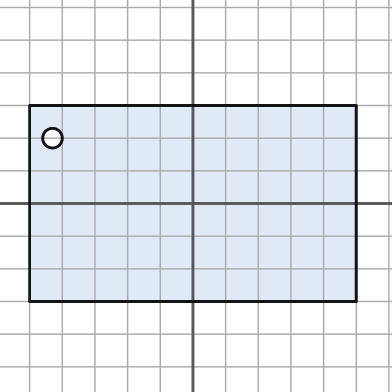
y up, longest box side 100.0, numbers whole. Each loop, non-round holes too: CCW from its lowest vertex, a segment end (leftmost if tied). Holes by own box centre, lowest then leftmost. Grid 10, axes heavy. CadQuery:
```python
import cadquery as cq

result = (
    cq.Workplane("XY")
    .moveTo(-50.0, -30.0)
    .lineTo(50.0, -30.0)
    .lineTo(50.0, 30.0)
    .lineTo(-50.0, 30.0)
    .close()
    .moveTo(-43.0, 20.0)
    .circle(3.0)
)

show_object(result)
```